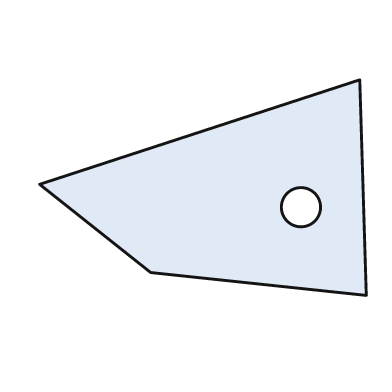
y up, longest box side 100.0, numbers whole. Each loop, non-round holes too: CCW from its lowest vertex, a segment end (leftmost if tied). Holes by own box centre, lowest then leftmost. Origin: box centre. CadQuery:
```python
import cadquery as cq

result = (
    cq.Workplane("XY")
    .moveTo(50.0, -33.0)
    .lineTo(48.0, 33.0)
    .lineTo(-50.0, 1.0)
    .lineTo(-16.0, -26.0)
    .close()
    .moveTo(30.0, -6.0)
    .circle(6.0)
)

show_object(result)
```